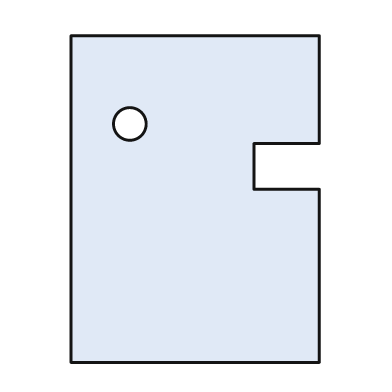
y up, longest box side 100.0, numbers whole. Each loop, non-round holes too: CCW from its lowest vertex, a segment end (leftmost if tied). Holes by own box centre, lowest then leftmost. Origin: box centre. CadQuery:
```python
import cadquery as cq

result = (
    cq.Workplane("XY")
    .moveTo(-38.0, -50.0)
    .lineTo(38.0, -50.0)
    .lineTo(38.0, 3.0)
    .lineTo(18.0, 3.0)
    .lineTo(18.0, 17.0)
    .lineTo(38.0, 17.0)
    .lineTo(38.0, 50.0)
    .lineTo(-38.0, 50.0)
    .close()
    .moveTo(-20.0, 23.0)
    .circle(5.0)
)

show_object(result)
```